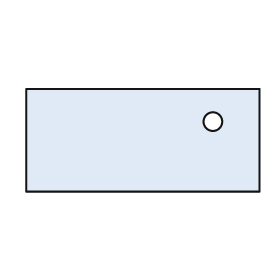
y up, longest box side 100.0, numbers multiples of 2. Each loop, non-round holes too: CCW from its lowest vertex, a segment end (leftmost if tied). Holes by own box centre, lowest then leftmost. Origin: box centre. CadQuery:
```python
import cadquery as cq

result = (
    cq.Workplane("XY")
    .moveTo(-50.0, -22.0)
    .lineTo(50.0, -22.0)
    .lineTo(50.0, 22.0)
    .lineTo(-50.0, 22.0)
    .close()
    .moveTo(30.0, 8.0)
    .circle(4.0)
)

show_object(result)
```